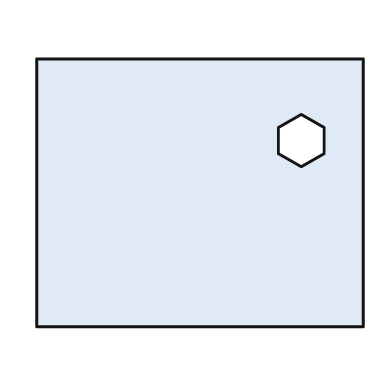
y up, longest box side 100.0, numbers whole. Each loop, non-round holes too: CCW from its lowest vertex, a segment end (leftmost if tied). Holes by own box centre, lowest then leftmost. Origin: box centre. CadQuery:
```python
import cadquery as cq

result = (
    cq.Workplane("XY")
    .moveTo(-50.0, -41.0)
    .lineTo(50.0, -41.0)
    .lineTo(50.0, 41.0)
    .lineTo(-50.0, 41.0)
    .close()
    .moveTo(31.0, 8.0)
    .lineTo(38.0, 12.0)
    .lineTo(38.0, 20.0)
    .lineTo(31.0, 24.0)
    .lineTo(24.0, 20.0)
    .lineTo(24.0, 12.0)
    .close()
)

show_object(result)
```